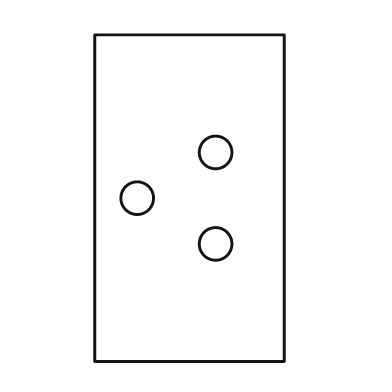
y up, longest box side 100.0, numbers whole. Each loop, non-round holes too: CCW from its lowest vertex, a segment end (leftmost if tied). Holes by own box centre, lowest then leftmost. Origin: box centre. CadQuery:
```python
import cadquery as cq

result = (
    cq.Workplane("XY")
    .moveTo(-29.0, -50.0)
    .lineTo(29.0, -50.0)
    .lineTo(29.0, 50.0)
    .lineTo(-29.0, 50.0)
    .close()
    .moveTo(8.0, -14.0)
    .circle(5.0)
    .moveTo(-16.0, 0.0)
    .circle(5.0)
    .moveTo(8.0, 14.0)
    .circle(5.0)
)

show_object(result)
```